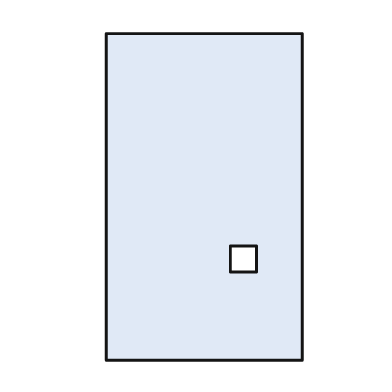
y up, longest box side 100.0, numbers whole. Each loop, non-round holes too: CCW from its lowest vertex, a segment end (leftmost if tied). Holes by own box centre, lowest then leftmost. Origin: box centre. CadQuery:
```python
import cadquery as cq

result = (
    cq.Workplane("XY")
    .moveTo(-30.0, -50.0)
    .lineTo(30.0, -50.0)
    .lineTo(30.0, 50.0)
    .lineTo(-30.0, 50.0)
    .close()
    .moveTo(8.0, -23.0)
    .lineTo(16.0, -23.0)
    .lineTo(16.0, -15.0)
    .lineTo(8.0, -15.0)
    .close()
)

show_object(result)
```